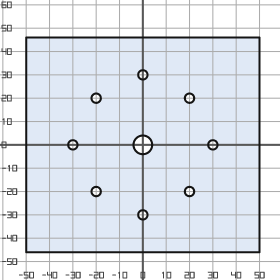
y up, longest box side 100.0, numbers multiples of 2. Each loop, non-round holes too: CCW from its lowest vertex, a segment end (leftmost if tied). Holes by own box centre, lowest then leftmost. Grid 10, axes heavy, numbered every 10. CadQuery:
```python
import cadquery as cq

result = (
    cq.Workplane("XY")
    .moveTo(-50.0, -46.0)
    .lineTo(50.0, -46.0)
    .lineTo(50.0, 46.0)
    .lineTo(-50.0, 46.0)
    .close()
    .moveTo(0.0, -30.0)
    .circle(2.0)
    .moveTo(-20.0, -20.0)
    .circle(2.0)
    .moveTo(20.0, -20.0)
    .circle(2.0)
    .moveTo(-30.0, 0.0)
    .circle(2.0)
    .moveTo(0.0, 0.0)
    .circle(4.0)
    .moveTo(30.0, 0.0)
    .circle(2.0)
    .moveTo(-20.0, 20.0)
    .circle(2.0)
    .moveTo(20.0, 20.0)
    .circle(2.0)
    .moveTo(0.0, 30.0)
    .circle(2.0)
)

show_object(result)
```